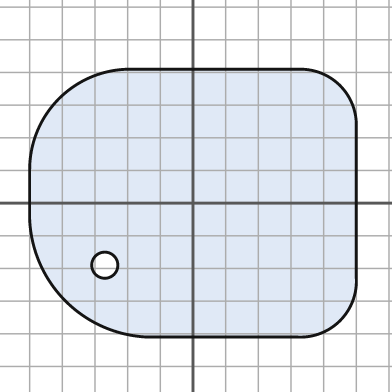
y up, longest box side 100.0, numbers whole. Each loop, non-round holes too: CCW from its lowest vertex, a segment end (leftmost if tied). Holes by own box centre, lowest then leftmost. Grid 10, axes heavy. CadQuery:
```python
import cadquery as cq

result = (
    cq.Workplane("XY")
    .moveTo(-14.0, -41.0)
    .lineTo(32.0, -41.0)
    .threePointArc((45.0, -36.0), (50.0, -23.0))
    .lineTo(50.0, 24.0)
    .threePointArc((45.0, 36.0), (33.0, 41.0))
    .lineTo(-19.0, 41.0)
    .threePointArc((-41.0, 32.0), (-50.0, 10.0))
    .lineTo(-50.0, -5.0)
    .threePointArc((-39.0, -30.0), (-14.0, -41.0))
    .close()
    .moveTo(-27.0, -19.0)
    .circle(4.0)
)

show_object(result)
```